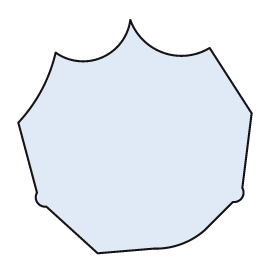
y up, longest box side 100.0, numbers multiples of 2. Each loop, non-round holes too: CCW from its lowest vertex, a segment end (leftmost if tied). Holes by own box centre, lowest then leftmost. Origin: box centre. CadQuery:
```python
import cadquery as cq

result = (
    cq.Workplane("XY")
    .moveTo(-16.0, -50.0)
    .lineTo(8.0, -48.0)
    .threePointArc((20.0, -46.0), (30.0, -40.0))
    .lineTo(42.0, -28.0)
    .threePointArc((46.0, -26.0), (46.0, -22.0))
    .lineTo(50.0, 10.0)
    .lineTo(32.0, 38.0)
    .threePointArc((12.0, 36.0), (-2.0, 50.0))
    .threePointArc((-14.0, 34.0), (-34.0, 36.0))
    .threePointArc((-40.0, 20.0), (-50.0, 6.0))
    .lineTo(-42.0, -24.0)
    .threePointArc((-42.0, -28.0), (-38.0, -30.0))
    .close()
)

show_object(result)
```